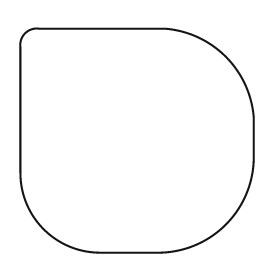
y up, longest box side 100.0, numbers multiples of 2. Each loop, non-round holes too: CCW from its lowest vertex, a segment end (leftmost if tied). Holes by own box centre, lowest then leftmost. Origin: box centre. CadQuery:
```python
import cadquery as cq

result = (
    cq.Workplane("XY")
    .moveTo(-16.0, -48.0)
    .lineTo(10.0, -48.0)
    .threePointArc((38.0, -36.0), (50.0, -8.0))
    .lineTo(50.0, 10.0)
    .threePointArc((38.0, 36.0), (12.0, 48.0))
    .lineTo(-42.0, 48.0)
    .threePointArc((-48.0, 46.0), (-50.0, 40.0))
    .lineTo(-50.0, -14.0)
    .threePointArc((-40.0, -38.0), (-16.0, -48.0))
    .close()
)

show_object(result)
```